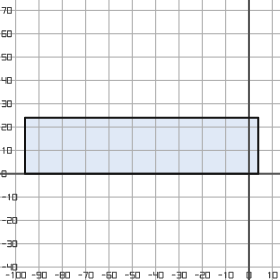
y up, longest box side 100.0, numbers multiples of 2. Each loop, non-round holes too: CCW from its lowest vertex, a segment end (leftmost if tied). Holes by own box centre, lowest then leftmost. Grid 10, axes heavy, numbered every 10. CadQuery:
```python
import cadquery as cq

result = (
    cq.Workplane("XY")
    .moveTo(-96.0, 0.0)
    .lineTo(4.0, 0.0)
    .lineTo(4.0, 24.0)
    .lineTo(-96.0, 24.0)
    .close()
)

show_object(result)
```